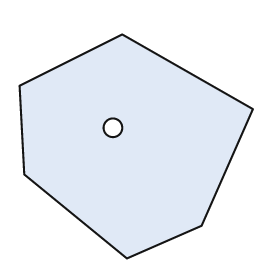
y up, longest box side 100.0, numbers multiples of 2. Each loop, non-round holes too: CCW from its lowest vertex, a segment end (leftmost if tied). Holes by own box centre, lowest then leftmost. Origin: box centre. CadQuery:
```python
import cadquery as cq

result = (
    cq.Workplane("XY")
    .moveTo(-4.0, -48.0)
    .lineTo(28.0, -34.0)
    .lineTo(50.0, 16.0)
    .lineTo(-6.0, 48.0)
    .lineTo(-50.0, 26.0)
    .lineTo(-48.0, -12.0)
    .close()
    .moveTo(-10.0, 8.0)
    .circle(4.0)
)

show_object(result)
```